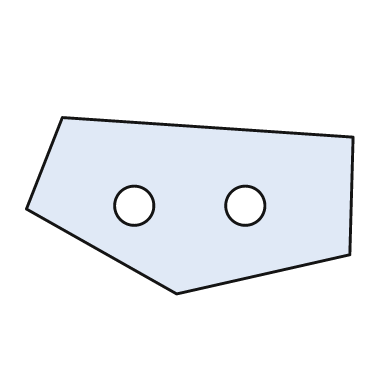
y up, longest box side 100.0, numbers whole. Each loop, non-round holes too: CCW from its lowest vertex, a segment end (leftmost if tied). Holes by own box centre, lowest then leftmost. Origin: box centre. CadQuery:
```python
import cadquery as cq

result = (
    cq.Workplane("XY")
    .moveTo(-4.0, -27.0)
    .lineTo(49.0, -15.0)
    .lineTo(50.0, 21.0)
    .lineTo(-39.0, 27.0)
    .lineTo(-50.0, -1.0)
    .close()
    .moveTo(-17.0, 0.0)
    .circle(6.0)
    .moveTo(17.0, 0.0)
    .circle(6.0)
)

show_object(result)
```